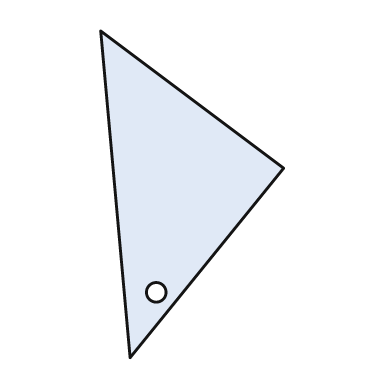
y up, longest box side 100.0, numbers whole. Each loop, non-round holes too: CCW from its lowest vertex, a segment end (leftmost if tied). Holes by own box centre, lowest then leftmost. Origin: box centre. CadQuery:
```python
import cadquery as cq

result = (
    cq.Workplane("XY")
    .moveTo(-19.0, -50.0)
    .lineTo(28.0, 8.0)
    .lineTo(-28.0, 50.0)
    .close()
    .moveTo(-11.0, -30.0)
    .circle(3.0)
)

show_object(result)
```